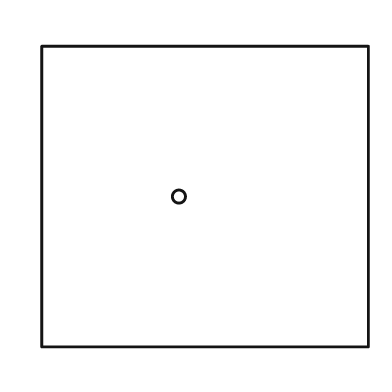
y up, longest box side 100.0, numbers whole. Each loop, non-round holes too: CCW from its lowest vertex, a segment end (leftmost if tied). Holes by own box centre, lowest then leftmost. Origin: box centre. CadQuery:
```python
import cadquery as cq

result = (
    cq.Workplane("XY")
    .moveTo(-50.0, -46.0)
    .lineTo(50.0, -46.0)
    .lineTo(50.0, 46.0)
    .lineTo(-50.0, 46.0)
    .close()
    .moveTo(-8.0, 0.0)
    .circle(2.0)
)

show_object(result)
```